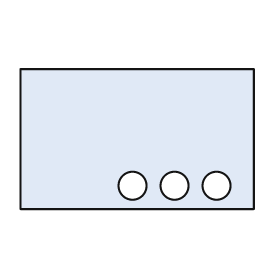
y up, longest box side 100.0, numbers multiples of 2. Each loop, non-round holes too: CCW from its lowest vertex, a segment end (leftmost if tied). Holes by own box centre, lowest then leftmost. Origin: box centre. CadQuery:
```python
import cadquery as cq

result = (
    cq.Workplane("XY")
    .moveTo(-50.0, -30.0)
    .lineTo(50.0, -30.0)
    .lineTo(50.0, 30.0)
    .lineTo(-50.0, 30.0)
    .close()
    .moveTo(-2.0, -20.0)
    .circle(6.0)
    .moveTo(16.0, -20.0)
    .circle(6.0)
    .moveTo(34.0, -20.0)
    .circle(6.0)
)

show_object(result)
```